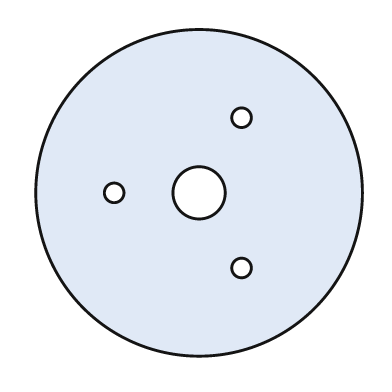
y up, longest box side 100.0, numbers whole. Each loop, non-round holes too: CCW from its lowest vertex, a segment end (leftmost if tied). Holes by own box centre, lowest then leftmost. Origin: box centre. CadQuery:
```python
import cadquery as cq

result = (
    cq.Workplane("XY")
    .moveTo(0.0, 0.0)
    .circle(50.0)
    .moveTo(13.0, -23.0)
    .circle(3.0)
    .moveTo(-26.0, 0.0)
    .circle(3.0)
    .moveTo(0.0, 0.0)
    .circle(8.0)
    .moveTo(13.0, 23.0)
    .circle(3.0)
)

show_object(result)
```